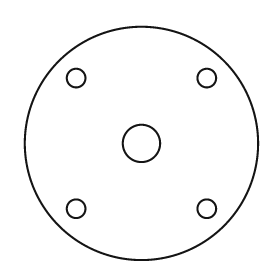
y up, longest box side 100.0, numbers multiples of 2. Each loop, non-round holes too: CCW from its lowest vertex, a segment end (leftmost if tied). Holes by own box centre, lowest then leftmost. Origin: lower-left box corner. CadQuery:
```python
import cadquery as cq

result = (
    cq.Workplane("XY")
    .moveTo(50.0, 50.0)
    .circle(50.0)
    .moveTo(22.0, 22.0)
    .circle(4.0)
    .moveTo(78.0, 22.0)
    .circle(4.0)
    .moveTo(50.0, 50.0)
    .circle(8.0)
    .moveTo(22.0, 78.0)
    .circle(4.0)
    .moveTo(78.0, 78.0)
    .circle(4.0)
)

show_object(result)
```